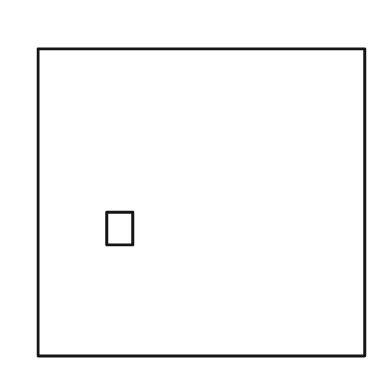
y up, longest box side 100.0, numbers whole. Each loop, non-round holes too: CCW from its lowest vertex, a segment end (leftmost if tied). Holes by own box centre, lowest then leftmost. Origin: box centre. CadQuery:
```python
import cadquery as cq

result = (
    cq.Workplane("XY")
    .moveTo(-50.0, -47.0)
    .lineTo(50.0, -47.0)
    .lineTo(50.0, 47.0)
    .lineTo(-50.0, 47.0)
    .close()
    .moveTo(-29.0, -13.0)
    .lineTo(-21.0, -13.0)
    .lineTo(-21.0, -3.0)
    .lineTo(-29.0, -3.0)
    .close()
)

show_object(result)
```